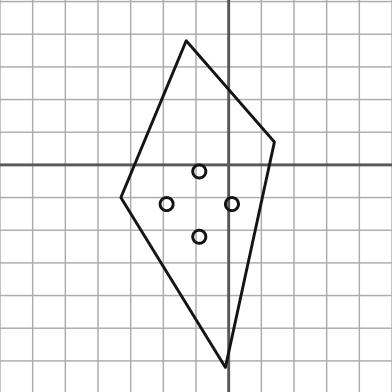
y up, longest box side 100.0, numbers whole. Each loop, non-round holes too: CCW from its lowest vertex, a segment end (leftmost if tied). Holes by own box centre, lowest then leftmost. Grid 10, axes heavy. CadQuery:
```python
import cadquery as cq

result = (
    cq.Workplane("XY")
    .moveTo(-1.0, -62.0)
    .lineTo(14.0, 7.0)
    .lineTo(-13.0, 38.0)
    .lineTo(-33.0, -10.0)
    .close()
    .moveTo(-9.0, -22.0)
    .circle(2.0)
    .moveTo(-19.0, -12.0)
    .circle(2.0)
    .moveTo(1.0, -12.0)
    .circle(2.0)
    .moveTo(-9.0, -2.0)
    .circle(2.0)
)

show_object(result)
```